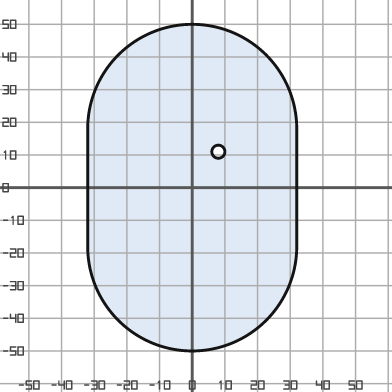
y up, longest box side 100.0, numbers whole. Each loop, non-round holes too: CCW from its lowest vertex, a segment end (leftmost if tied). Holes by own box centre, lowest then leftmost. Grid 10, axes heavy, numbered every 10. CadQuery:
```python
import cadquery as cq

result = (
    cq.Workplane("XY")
    .moveTo(-32.0, -18.0)
    .threePointArc((0.0, -50.0), (32.0, -18.0))
    .lineTo(32.0, 18.0)
    .threePointArc((0.0, 50.0), (-32.0, 18.0))
    .close()
    .moveTo(8.0, 11.0)
    .circle(2.0)
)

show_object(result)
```